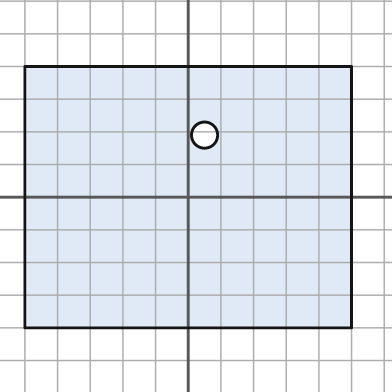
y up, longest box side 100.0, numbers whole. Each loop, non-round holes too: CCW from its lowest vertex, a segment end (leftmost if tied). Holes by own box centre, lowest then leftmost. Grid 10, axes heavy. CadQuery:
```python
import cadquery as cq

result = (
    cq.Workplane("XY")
    .moveTo(-50.0, -40.0)
    .lineTo(50.0, -40.0)
    .lineTo(50.0, 40.0)
    .lineTo(-50.0, 40.0)
    .close()
    .moveTo(5.0, 19.0)
    .circle(4.0)
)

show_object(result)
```